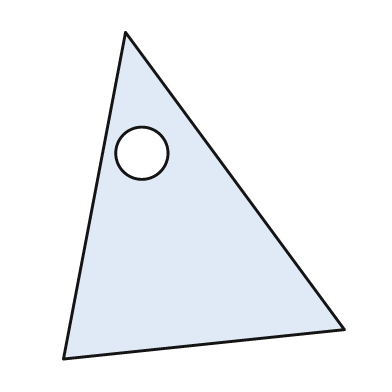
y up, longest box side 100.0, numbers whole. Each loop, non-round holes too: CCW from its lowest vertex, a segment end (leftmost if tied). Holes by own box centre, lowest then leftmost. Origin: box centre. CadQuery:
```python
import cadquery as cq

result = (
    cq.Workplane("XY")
    .moveTo(-43.0, -50.0)
    .lineTo(43.0, -41.0)
    .lineTo(-24.0, 50.0)
    .close()
    .moveTo(-19.0, 13.0)
    .circle(8.0)
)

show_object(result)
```